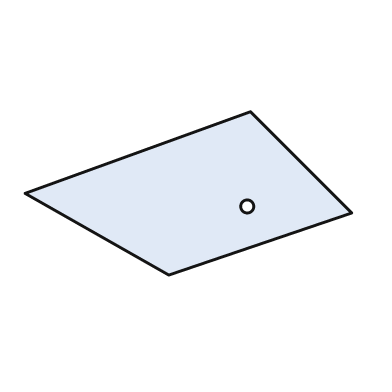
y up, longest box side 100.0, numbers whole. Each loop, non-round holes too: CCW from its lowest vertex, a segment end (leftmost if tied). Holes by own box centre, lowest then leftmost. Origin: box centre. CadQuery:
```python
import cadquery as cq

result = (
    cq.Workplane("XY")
    .moveTo(-6.0, -25.0)
    .lineTo(50.0, -6.0)
    .lineTo(19.0, 25.0)
    .lineTo(-50.0, 0.0)
    .close()
    .moveTo(18.0, -4.0)
    .circle(2.0)
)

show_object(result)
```